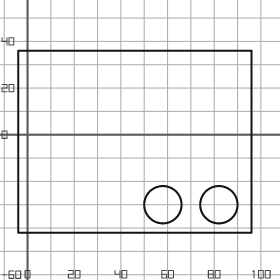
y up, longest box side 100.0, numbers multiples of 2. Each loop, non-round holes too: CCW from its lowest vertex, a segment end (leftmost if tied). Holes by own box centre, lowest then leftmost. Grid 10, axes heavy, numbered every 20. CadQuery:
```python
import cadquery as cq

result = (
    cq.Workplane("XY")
    .moveTo(-4.0, -42.0)
    .lineTo(96.0, -42.0)
    .lineTo(96.0, 36.0)
    .lineTo(-4.0, 36.0)
    .close()
    .moveTo(58.0, -30.0)
    .circle(8.0)
    .moveTo(82.0, -30.0)
    .circle(8.0)
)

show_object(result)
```